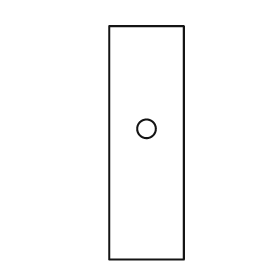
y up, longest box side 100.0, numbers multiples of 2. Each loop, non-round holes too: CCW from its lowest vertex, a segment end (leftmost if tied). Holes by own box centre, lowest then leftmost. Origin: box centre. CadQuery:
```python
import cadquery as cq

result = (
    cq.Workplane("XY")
    .moveTo(-16.0, -50.0)
    .lineTo(16.0, -50.0)
    .lineTo(16.0, 50.0)
    .lineTo(-16.0, 50.0)
    .close()
    .moveTo(0.0, 6.0)
    .circle(4.0)
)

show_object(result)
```